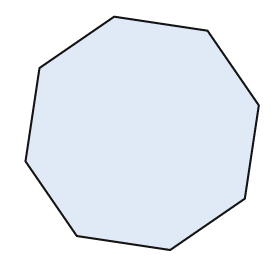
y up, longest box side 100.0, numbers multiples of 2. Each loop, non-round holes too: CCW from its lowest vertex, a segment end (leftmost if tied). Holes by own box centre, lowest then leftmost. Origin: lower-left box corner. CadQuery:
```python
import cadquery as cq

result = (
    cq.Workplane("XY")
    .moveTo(62.0, 0.0)
    .lineTo(94.0, 22.0)
    .lineTo(100.0, 62.0)
    .lineTo(78.0, 94.0)
    .lineTo(38.0, 100.0)
    .lineTo(6.0, 78.0)
    .lineTo(0.0, 38.0)
    .lineTo(22.0, 6.0)
    .close()
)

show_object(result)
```